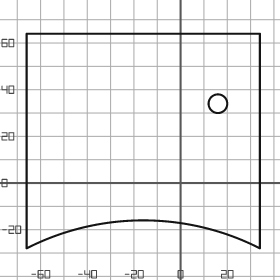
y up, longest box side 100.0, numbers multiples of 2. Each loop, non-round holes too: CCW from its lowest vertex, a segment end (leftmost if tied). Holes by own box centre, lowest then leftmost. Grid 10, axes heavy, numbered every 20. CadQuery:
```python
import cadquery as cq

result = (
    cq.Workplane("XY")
    .moveTo(-66.0, -28.0)
    .threePointArc((-16.0, -16.0), (34.0, -28.0))
    .lineTo(34.0, 64.0)
    .lineTo(-66.0, 64.0)
    .close()
    .moveTo(16.0, 34.0)
    .circle(4.0)
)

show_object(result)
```